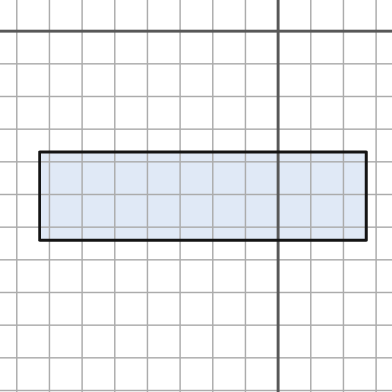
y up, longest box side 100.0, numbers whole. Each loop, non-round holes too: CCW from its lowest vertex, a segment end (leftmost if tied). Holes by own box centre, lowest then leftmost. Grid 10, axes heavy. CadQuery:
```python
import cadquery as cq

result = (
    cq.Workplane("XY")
    .moveTo(-73.0, -64.0)
    .lineTo(27.0, -64.0)
    .lineTo(27.0, -37.0)
    .lineTo(-73.0, -37.0)
    .close()
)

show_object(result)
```